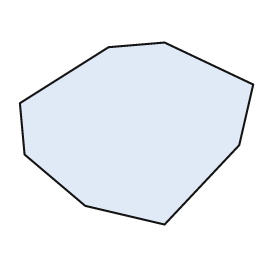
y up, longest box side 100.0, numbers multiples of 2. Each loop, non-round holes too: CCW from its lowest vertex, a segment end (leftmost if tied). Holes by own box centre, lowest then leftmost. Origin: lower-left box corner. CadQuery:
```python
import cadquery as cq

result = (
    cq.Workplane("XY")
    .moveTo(62.0, 0.0)
    .lineTo(94.0, 34.0)
    .lineTo(100.0, 60.0)
    .lineTo(62.0, 78.0)
    .lineTo(38.0, 76.0)
    .lineTo(0.0, 52.0)
    .lineTo(2.0, 30.0)
    .lineTo(28.0, 8.0)
    .close()
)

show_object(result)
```